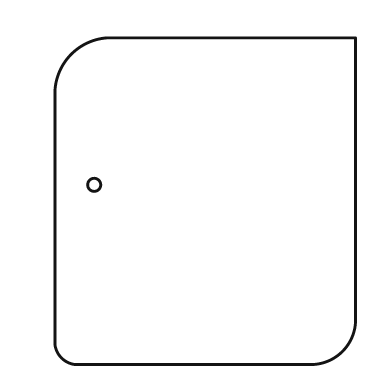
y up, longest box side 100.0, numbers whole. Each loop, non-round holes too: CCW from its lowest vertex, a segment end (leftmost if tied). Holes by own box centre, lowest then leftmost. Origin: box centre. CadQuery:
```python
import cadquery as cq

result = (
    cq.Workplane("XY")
    .moveTo(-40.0, -50.0)
    .lineTo(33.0, -50.0)
    .threePointArc((42.0, -46.0), (46.0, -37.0))
    .lineTo(46.0, 50.0)
    .lineTo(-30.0, 50.0)
    .threePointArc((-41.0, 45.0), (-46.0, 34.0))
    .lineTo(-46.0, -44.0)
    .threePointArc((-44.0, -48.0), (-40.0, -50.0))
    .close()
    .moveTo(-34.0, 5.0)
    .circle(2.0)
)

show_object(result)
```